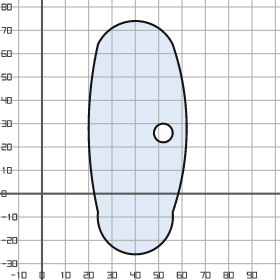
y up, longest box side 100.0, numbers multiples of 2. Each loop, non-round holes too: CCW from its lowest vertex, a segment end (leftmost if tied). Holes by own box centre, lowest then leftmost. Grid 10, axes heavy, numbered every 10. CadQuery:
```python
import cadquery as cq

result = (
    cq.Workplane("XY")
    .moveTo(24.0, -8.0)
    .threePointArc((40.0, -26.0), (56.0, -8.0))
    .threePointArc((62.0, 28.0), (56.0, 64.0))
    .threePointArc((40.0, 74.0), (24.0, 64.0))
    .threePointArc((20.0, 28.0), (24.0, -8.0))
    .close()
    .moveTo(52.0, 26.0)
    .circle(4.0)
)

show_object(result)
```